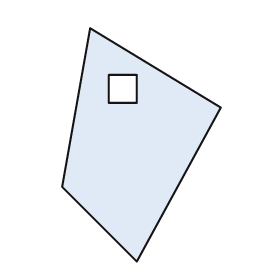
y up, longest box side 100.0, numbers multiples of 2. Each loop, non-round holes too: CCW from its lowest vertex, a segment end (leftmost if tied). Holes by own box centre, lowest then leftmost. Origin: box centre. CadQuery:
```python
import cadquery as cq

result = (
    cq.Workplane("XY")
    .moveTo(-2.0, -50.0)
    .lineTo(34.0, 16.0)
    .lineTo(-22.0, 50.0)
    .lineTo(-34.0, -18.0)
    .close()
    .moveTo(-14.0, 18.0)
    .lineTo(-2.0, 18.0)
    .lineTo(-2.0, 30.0)
    .lineTo(-14.0, 30.0)
    .close()
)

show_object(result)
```